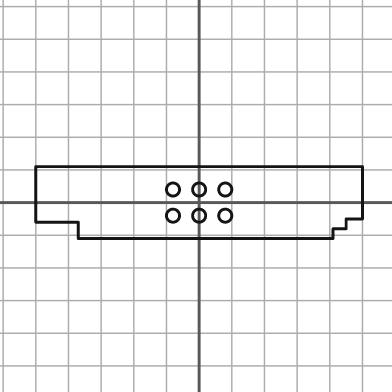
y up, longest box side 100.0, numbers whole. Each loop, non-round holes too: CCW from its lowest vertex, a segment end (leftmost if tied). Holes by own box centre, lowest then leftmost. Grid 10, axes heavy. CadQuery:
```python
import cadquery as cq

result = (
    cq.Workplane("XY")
    .moveTo(-37.0, -11.0)
    .lineTo(41.0, -11.0)
    .lineTo(41.0, -8.0)
    .lineTo(45.0, -8.0)
    .lineTo(45.0, -5.0)
    .lineTo(50.0, -5.0)
    .lineTo(50.0, 11.0)
    .lineTo(-50.0, 11.0)
    .lineTo(-50.0, -6.0)
    .lineTo(-37.0, -6.0)
    .close()
    .moveTo(-8.0, -4.0)
    .circle(2.0)
    .moveTo(0.0, -4.0)
    .circle(2.0)
    .moveTo(8.0, -4.0)
    .circle(2.0)
    .moveTo(-8.0, 4.0)
    .circle(2.0)
    .moveTo(0.0, 4.0)
    .circle(2.0)
    .moveTo(8.0, 4.0)
    .circle(2.0)
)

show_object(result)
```